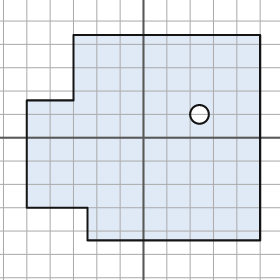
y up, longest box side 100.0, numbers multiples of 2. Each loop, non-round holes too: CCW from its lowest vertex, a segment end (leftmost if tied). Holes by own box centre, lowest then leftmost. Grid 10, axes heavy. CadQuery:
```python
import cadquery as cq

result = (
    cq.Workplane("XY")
    .moveTo(-24.0, -44.0)
    .lineTo(50.0, -44.0)
    .lineTo(50.0, 44.0)
    .lineTo(-30.0, 44.0)
    .lineTo(-30.0, 16.0)
    .lineTo(-50.0, 16.0)
    .lineTo(-50.0, -30.0)
    .lineTo(-24.0, -30.0)
    .close()
    .moveTo(24.0, 10.0)
    .circle(4.0)
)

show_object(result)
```